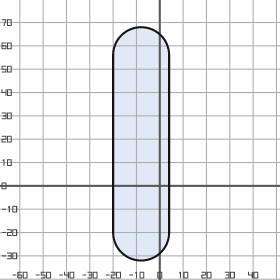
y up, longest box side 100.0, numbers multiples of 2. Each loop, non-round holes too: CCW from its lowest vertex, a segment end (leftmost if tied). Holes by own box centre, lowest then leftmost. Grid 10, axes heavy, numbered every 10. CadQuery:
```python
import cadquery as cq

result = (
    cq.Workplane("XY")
    .moveTo(-20.0, -20.0)
    .threePointArc((-8.0, -32.0), (4.0, -20.0))
    .lineTo(4.0, 56.0)
    .threePointArc((-8.0, 68.0), (-20.0, 56.0))
    .close()
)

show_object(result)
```